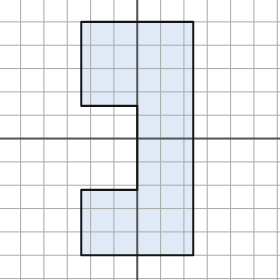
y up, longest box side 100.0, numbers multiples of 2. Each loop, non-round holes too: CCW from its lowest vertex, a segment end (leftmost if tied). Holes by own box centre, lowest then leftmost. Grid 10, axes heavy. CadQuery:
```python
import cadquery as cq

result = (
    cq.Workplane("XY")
    .moveTo(-24.0, -50.0)
    .lineTo(24.0, -50.0)
    .lineTo(24.0, 50.0)
    .lineTo(-24.0, 50.0)
    .lineTo(-24.0, 14.0)
    .lineTo(0.0, 14.0)
    .lineTo(0.0, -22.0)
    .lineTo(-24.0, -22.0)
    .close()
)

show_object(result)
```